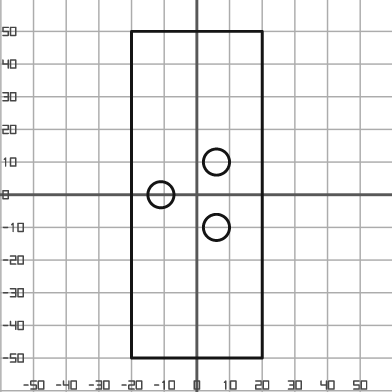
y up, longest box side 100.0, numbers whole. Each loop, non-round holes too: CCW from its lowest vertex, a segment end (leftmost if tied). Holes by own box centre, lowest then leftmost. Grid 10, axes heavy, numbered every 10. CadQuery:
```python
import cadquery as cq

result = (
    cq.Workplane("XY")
    .moveTo(-20.0, -50.0)
    .lineTo(20.0, -50.0)
    .lineTo(20.0, 50.0)
    .lineTo(-20.0, 50.0)
    .close()
    .moveTo(6.0, -10.0)
    .circle(4.0)
    .moveTo(-11.0, 0.0)
    .circle(4.0)
    .moveTo(6.0, 10.0)
    .circle(4.0)
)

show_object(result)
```